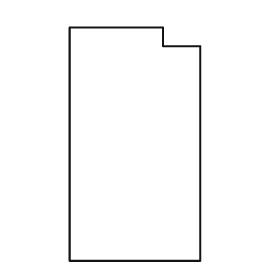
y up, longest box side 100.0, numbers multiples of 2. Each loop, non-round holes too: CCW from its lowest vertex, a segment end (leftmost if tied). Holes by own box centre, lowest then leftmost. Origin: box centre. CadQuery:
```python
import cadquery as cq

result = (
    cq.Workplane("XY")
    .moveTo(-28.0, -50.0)
    .lineTo(28.0, -50.0)
    .lineTo(28.0, 42.0)
    .lineTo(12.0, 42.0)
    .lineTo(12.0, 50.0)
    .lineTo(-28.0, 50.0)
    .close()
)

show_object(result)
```